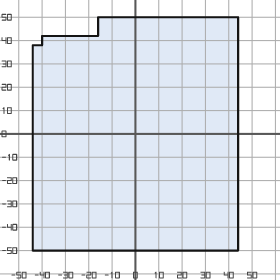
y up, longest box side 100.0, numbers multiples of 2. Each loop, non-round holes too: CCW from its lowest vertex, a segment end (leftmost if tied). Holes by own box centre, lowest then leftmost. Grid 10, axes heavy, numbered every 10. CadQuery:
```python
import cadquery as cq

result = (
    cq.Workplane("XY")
    .moveTo(-44.0, -50.0)
    .lineTo(44.0, -50.0)
    .lineTo(44.0, 50.0)
    .lineTo(-16.0, 50.0)
    .lineTo(-16.0, 42.0)
    .lineTo(-40.0, 42.0)
    .lineTo(-40.0, 38.0)
    .lineTo(-44.0, 38.0)
    .close()
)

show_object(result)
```